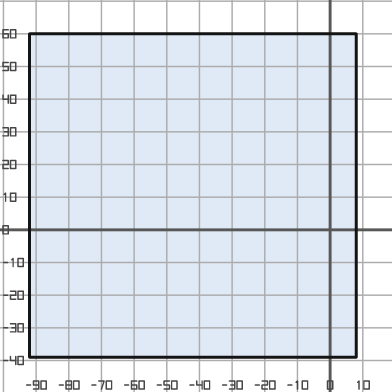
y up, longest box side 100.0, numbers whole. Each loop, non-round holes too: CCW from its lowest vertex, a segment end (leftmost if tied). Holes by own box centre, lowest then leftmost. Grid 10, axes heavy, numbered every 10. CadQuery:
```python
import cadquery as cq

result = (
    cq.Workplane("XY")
    .moveTo(-92.0, -39.0)
    .lineTo(8.0, -39.0)
    .lineTo(8.0, 60.0)
    .lineTo(-92.0, 60.0)
    .close()
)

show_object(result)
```